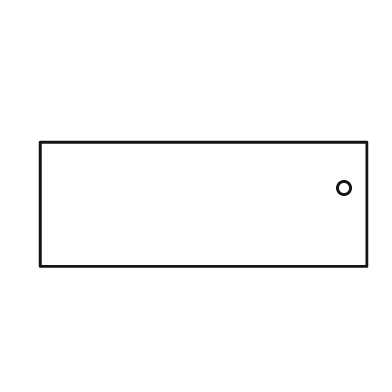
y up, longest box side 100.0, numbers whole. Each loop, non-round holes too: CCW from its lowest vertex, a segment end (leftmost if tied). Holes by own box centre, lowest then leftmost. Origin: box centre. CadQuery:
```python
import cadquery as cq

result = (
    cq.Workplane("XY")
    .moveTo(-50.0, -19.0)
    .lineTo(50.0, -19.0)
    .lineTo(50.0, 19.0)
    .lineTo(-50.0, 19.0)
    .close()
    .moveTo(43.0, 5.0)
    .circle(2.0)
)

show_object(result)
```